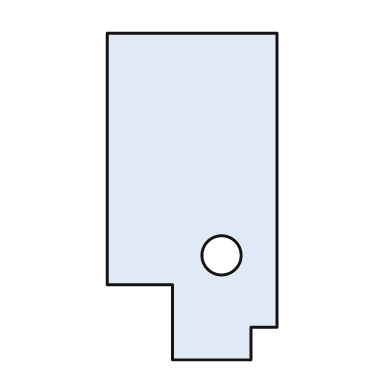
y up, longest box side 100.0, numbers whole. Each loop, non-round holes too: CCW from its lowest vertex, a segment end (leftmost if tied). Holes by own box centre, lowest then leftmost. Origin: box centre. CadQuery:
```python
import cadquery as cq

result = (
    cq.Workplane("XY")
    .moveTo(-6.0, -50.0)
    .lineTo(18.0, -50.0)
    .lineTo(18.0, -40.0)
    .lineTo(26.0, -40.0)
    .lineTo(26.0, 50.0)
    .lineTo(-26.0, 50.0)
    .lineTo(-26.0, -27.0)
    .lineTo(-6.0, -27.0)
    .close()
    .moveTo(9.0, -18.0)
    .circle(6.0)
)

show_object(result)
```